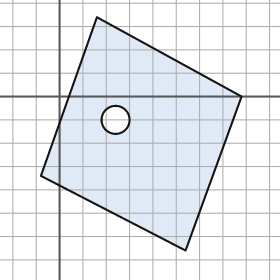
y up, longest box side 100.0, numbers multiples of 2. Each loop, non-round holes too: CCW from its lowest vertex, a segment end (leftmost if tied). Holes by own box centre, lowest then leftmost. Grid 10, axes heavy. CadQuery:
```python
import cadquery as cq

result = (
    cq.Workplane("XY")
    .moveTo(54.0, -66.0)
    .lineTo(78.0, 0.0)
    .lineTo(16.0, 34.0)
    .lineTo(-8.0, -34.0)
    .close()
    .moveTo(24.0, -10.0)
    .circle(6.0)
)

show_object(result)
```